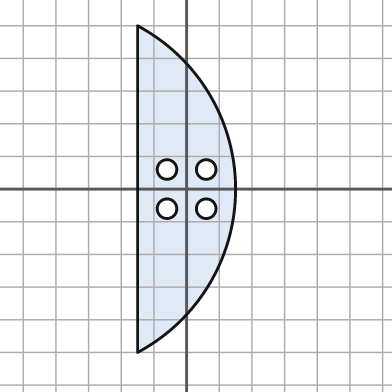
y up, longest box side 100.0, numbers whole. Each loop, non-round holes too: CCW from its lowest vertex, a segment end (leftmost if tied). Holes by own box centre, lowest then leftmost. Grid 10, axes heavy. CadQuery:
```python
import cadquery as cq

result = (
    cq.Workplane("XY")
    .moveTo(-15.0, -50.0)
    .threePointArc((15.0, 0.0), (-15.0, 50.0))
    .close()
    .moveTo(-6.0, -6.0)
    .circle(3.0)
    .moveTo(6.0, -6.0)
    .circle(3.0)
    .moveTo(-6.0, 6.0)
    .circle(3.0)
    .moveTo(6.0, 6.0)
    .circle(3.0)
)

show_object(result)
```